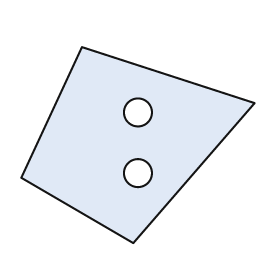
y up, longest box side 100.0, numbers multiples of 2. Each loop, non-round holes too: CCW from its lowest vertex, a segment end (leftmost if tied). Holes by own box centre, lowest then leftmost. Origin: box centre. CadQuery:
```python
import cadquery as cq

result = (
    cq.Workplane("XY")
    .moveTo(-2.0, -42.0)
    .lineTo(50.0, 18.0)
    .lineTo(-24.0, 42.0)
    .lineTo(-50.0, -14.0)
    .close()
    .moveTo(0.0, -12.0)
    .circle(6.0)
    .moveTo(0.0, 14.0)
    .circle(6.0)
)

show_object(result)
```